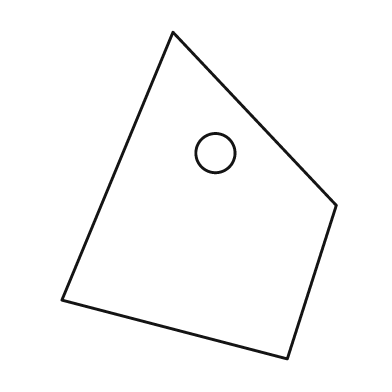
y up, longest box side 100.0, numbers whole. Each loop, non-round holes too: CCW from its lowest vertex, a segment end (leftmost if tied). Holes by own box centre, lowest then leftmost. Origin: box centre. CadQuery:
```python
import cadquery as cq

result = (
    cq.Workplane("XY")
    .moveTo(27.0, -50.0)
    .lineTo(42.0, -3.0)
    .lineTo(-8.0, 50.0)
    .lineTo(-42.0, -32.0)
    .close()
    .moveTo(5.0, 13.0)
    .circle(6.0)
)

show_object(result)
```